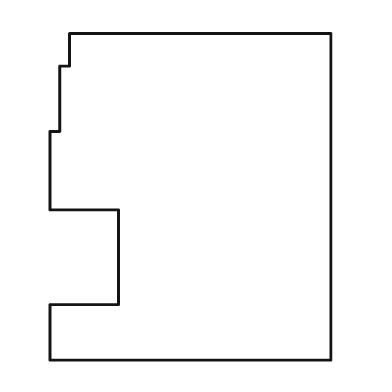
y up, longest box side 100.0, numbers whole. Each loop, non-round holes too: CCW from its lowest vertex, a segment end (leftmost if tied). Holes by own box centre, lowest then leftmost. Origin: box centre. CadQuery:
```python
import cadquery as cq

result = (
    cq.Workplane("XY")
    .moveTo(-43.0, -50.0)
    .lineTo(43.0, -50.0)
    .lineTo(43.0, 50.0)
    .lineTo(-37.0, 50.0)
    .lineTo(-37.0, 40.0)
    .lineTo(-40.0, 40.0)
    .lineTo(-40.0, 20.0)
    .lineTo(-43.0, 20.0)
    .lineTo(-43.0, -4.0)
    .lineTo(-22.0, -4.0)
    .lineTo(-22.0, -33.0)
    .lineTo(-43.0, -33.0)
    .close()
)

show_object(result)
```